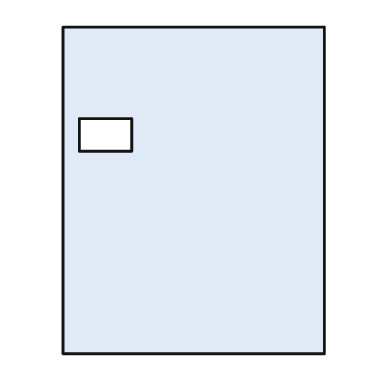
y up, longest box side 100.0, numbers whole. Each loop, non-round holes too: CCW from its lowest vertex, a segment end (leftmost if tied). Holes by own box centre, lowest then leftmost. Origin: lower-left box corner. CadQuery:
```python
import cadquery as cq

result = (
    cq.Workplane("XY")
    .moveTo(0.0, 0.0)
    .lineTo(80.0, 0.0)
    .lineTo(80.0, 100.0)
    .lineTo(0.0, 100.0)
    .close()
    .moveTo(5.0, 62.0)
    .lineTo(21.0, 62.0)
    .lineTo(21.0, 72.0)
    .lineTo(5.0, 72.0)
    .close()
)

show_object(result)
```